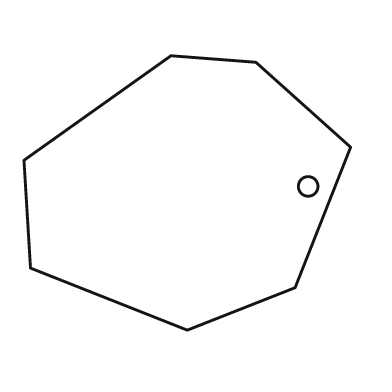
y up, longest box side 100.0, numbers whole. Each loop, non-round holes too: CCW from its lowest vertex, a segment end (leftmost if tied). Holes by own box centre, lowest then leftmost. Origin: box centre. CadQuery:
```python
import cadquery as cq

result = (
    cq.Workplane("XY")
    .moveTo(0.0, -42.0)
    .lineTo(33.0, -29.0)
    .lineTo(50.0, 14.0)
    .lineTo(21.0, 40.0)
    .lineTo(-5.0, 42.0)
    .lineTo(-50.0, 10.0)
    .lineTo(-48.0, -23.0)
    .close()
    .moveTo(37.0, 2.0)
    .circle(3.0)
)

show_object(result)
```